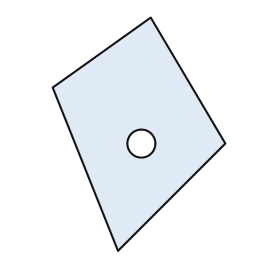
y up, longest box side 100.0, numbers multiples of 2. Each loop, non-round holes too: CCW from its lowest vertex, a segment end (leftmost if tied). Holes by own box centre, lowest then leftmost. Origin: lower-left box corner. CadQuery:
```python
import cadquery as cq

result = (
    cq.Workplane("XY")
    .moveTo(28.0, 0.0)
    .lineTo(74.0, 46.0)
    .lineTo(42.0, 100.0)
    .lineTo(0.0, 70.0)
    .close()
    .moveTo(38.0, 46.0)
    .circle(6.0)
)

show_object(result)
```